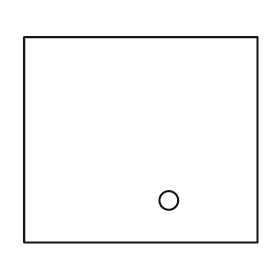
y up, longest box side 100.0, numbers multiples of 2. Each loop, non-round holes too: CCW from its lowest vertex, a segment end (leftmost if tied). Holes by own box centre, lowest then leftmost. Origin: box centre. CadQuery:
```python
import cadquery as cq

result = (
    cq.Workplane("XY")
    .moveTo(-50.0, -44.0)
    .lineTo(50.0, -44.0)
    .lineTo(50.0, 44.0)
    .lineTo(-50.0, 44.0)
    .close()
    .moveTo(12.0, -26.0)
    .circle(4.0)
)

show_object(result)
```